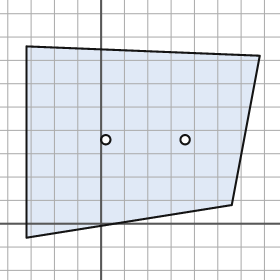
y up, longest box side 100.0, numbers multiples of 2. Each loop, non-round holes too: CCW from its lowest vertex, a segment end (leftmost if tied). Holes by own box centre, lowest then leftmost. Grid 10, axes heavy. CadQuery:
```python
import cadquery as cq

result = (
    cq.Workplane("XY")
    .moveTo(-32.0, -6.0)
    .lineTo(56.0, 8.0)
    .lineTo(68.0, 72.0)
    .lineTo(-32.0, 76.0)
    .close()
    .moveTo(2.0, 36.0)
    .circle(2.0)
    .moveTo(36.0, 36.0)
    .circle(2.0)
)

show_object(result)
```